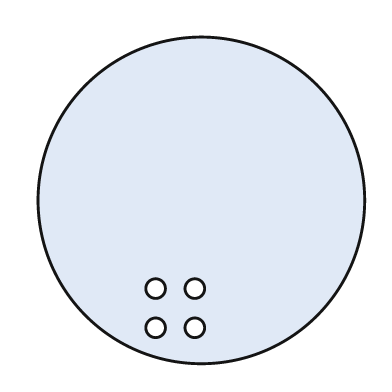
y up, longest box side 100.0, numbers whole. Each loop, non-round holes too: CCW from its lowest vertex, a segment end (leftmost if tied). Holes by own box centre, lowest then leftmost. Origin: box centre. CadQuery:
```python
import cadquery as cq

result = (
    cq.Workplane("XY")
    .moveTo(0.0, 0.0)
    .circle(50.0)
    .moveTo(-14.0, -39.0)
    .circle(3.0)
    .moveTo(-2.0, -39.0)
    .circle(3.0)
    .moveTo(-14.0, -27.0)
    .circle(3.0)
    .moveTo(-2.0, -27.0)
    .circle(3.0)
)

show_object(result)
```